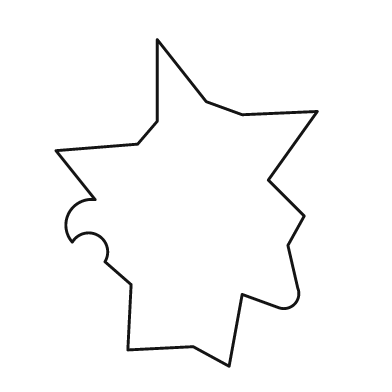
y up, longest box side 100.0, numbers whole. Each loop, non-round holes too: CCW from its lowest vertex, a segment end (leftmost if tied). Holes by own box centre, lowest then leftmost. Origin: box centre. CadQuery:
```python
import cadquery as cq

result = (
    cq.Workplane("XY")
    .moveTo(13.0, -50.0)
    .lineTo(17.0, -28.0)
    .lineTo(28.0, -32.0)
    .threePointArc((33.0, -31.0), (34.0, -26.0))
    .lineTo(31.0, -13.0)
    .lineTo(36.0, -4.0)
    .lineTo(25.0, 7.0)
    .lineTo(40.0, 28.0)
    .lineTo(17.0, 27.0)
    .lineTo(6.0, 31.0)
    .lineTo(-9.0, 50.0)
    .lineTo(-9.0, 25.0)
    .lineTo(-15.0, 18.0)
    .lineTo(-40.0, 16.0)
    .lineTo(-28.0, 1.0)
    .threePointArc((-36.0, -3.0), (-35.0, -12.0))
    .threePointArc((-27.0, -10.0), (-25.0, -18.0))
    .lineTo(-17.0, -25.0)
    .lineTo(-18.0, -45.0)
    .lineTo(2.0, -44.0)
    .close()
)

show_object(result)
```